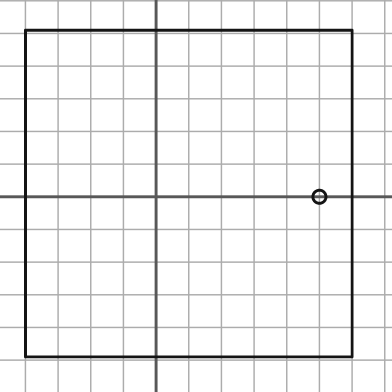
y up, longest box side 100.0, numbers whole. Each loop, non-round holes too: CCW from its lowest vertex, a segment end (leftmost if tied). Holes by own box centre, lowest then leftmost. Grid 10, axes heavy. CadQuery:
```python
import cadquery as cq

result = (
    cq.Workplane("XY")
    .moveTo(-40.0, -49.0)
    .lineTo(60.0, -49.0)
    .lineTo(60.0, 51.0)
    .lineTo(-40.0, 51.0)
    .close()
    .moveTo(50.0, 0.0)
    .circle(2.0)
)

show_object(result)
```